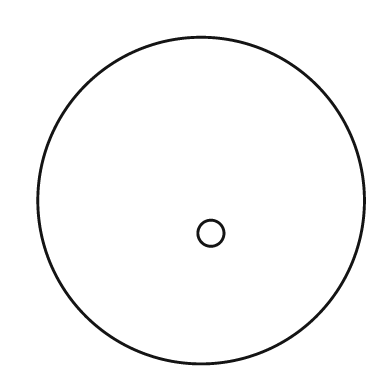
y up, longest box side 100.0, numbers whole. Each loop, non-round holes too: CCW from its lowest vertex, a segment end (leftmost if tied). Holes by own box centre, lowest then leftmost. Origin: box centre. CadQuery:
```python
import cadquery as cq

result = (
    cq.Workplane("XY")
    .moveTo(0.0, 0.0)
    .circle(50.0)
    .moveTo(3.0, -10.0)
    .circle(4.0)
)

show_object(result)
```